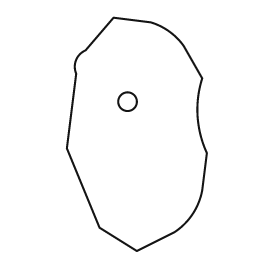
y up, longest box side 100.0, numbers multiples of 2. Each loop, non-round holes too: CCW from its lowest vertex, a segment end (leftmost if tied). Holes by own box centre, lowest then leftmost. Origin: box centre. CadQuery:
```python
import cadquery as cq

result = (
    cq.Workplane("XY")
    .moveTo(0.0, -50.0)
    .lineTo(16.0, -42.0)
    .threePointArc((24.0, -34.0), (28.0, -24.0))
    .lineTo(30.0, -8.0)
    .threePointArc((26.0, 8.0), (28.0, 24.0))
    .lineTo(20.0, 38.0)
    .threePointArc((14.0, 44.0), (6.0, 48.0))
    .lineTo(-10.0, 50.0)
    .lineTo(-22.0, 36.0)
    .threePointArc((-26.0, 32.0), (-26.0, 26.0))
    .lineTo(-30.0, -6.0)
    .lineTo(-16.0, -40.0)
    .close()
    .moveTo(-4.0, 14.0)
    .circle(4.0)
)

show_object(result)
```